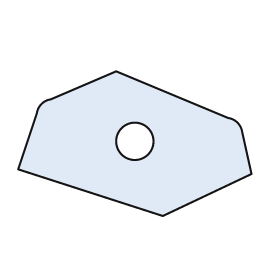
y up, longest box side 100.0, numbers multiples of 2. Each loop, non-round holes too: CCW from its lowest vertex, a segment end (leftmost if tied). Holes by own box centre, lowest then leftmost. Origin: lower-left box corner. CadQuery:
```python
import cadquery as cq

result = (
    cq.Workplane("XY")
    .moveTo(62.0, 0.0)
    .lineTo(100.0, 18.0)
    .lineTo(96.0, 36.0)
    .threePointArc((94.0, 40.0), (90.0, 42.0))
    .lineTo(42.0, 62.0)
    .lineTo(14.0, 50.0)
    .threePointArc((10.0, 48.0), (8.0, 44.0))
    .lineTo(0.0, 20.0)
    .close()
    .moveTo(50.0, 32.0)
    .circle(8.0)
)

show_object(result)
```